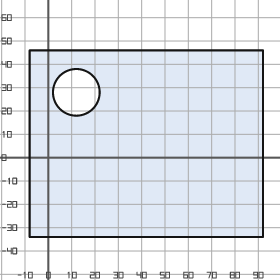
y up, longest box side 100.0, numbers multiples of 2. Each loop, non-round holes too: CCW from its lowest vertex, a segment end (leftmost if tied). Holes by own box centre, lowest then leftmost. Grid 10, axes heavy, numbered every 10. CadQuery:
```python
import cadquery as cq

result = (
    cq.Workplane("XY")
    .moveTo(-8.0, -34.0)
    .lineTo(92.0, -34.0)
    .lineTo(92.0, 46.0)
    .lineTo(-8.0, 46.0)
    .close()
    .moveTo(12.0, 28.0)
    .circle(10.0)
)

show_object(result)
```